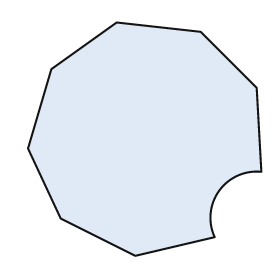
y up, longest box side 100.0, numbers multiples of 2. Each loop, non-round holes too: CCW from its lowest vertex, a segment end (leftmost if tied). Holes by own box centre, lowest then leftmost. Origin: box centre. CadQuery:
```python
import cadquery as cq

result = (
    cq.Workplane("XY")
    .moveTo(-4.0, -50.0)
    .lineTo(30.0, -42.0)
    .threePointArc((32.0, -22.0), (50.0, -14.0))
    .lineTo(48.0, 22.0)
    .lineTo(24.0, 46.0)
    .lineTo(-12.0, 50.0)
    .lineTo(-40.0, 30.0)
    .lineTo(-50.0, -4.0)
    .lineTo(-36.0, -34.0)
    .close()
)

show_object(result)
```